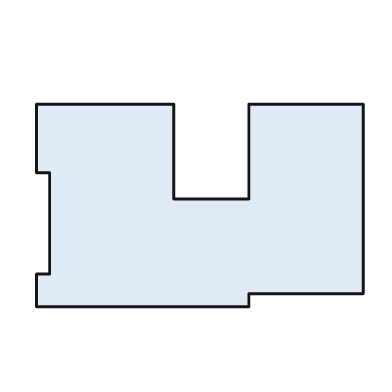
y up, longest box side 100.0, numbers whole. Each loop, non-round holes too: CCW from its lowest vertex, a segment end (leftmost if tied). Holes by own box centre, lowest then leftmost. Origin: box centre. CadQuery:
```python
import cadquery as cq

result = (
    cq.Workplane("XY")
    .moveTo(-50.0, -31.0)
    .lineTo(15.0, -31.0)
    .lineTo(15.0, -27.0)
    .lineTo(50.0, -27.0)
    .lineTo(50.0, 31.0)
    .lineTo(15.0, 31.0)
    .lineTo(15.0, 2.0)
    .lineTo(-8.0, 2.0)
    .lineTo(-8.0, 31.0)
    .lineTo(-50.0, 31.0)
    .lineTo(-50.0, 10.0)
    .lineTo(-46.0, 10.0)
    .lineTo(-46.0, -21.0)
    .lineTo(-50.0, -21.0)
    .close()
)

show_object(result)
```